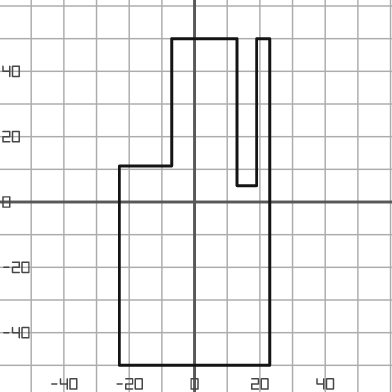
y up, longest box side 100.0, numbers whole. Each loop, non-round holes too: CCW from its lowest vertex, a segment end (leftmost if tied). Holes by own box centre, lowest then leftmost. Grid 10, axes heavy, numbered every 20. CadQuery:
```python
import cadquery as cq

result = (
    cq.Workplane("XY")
    .moveTo(-23.0, -50.0)
    .lineTo(23.0, -50.0)
    .lineTo(23.0, 50.0)
    .lineTo(19.0, 50.0)
    .lineTo(19.0, 5.0)
    .lineTo(13.0, 5.0)
    .lineTo(13.0, 50.0)
    .lineTo(-7.0, 50.0)
    .lineTo(-7.0, 11.0)
    .lineTo(-23.0, 11.0)
    .close()
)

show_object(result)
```